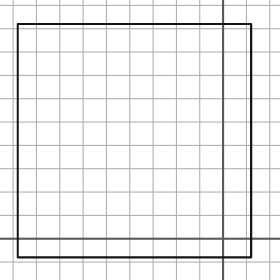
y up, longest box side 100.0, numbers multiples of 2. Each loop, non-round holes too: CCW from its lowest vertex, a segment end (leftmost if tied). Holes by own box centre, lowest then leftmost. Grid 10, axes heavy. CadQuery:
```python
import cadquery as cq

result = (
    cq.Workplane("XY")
    .moveTo(-88.0, -8.0)
    .lineTo(12.0, -8.0)
    .lineTo(12.0, 92.0)
    .lineTo(-88.0, 92.0)
    .close()
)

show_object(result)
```